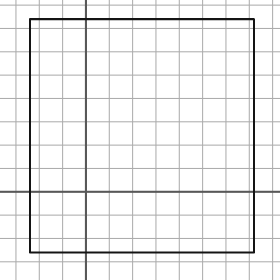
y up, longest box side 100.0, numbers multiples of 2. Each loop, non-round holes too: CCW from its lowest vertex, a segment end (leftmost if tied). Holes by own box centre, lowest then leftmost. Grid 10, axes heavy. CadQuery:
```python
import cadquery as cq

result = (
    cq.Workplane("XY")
    .moveTo(-24.0, -26.0)
    .lineTo(72.0, -26.0)
    .lineTo(72.0, 74.0)
    .lineTo(-24.0, 74.0)
    .close()
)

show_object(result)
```